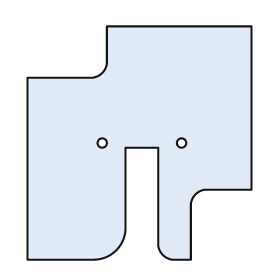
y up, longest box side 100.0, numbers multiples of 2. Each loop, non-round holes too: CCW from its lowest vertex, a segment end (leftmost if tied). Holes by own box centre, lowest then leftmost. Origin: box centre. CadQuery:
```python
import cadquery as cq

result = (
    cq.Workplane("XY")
    .moveTo(-48.0, -50.0)
    .lineTo(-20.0, -50.0)
    .threePointArc((-10.0, -46.0), (-6.0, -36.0))
    .lineTo(-6.0, -2.0)
    .lineTo(8.0, -2.0)
    .lineTo(8.0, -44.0)
    .threePointArc((10.0, -48.0), (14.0, -50.0))
    .lineTo(22.0, -50.0)
    .lineTo(22.0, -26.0)
    .threePointArc((24.0, -22.0), (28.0, -20.0))
    .lineTo(48.0, -20.0)
    .lineTo(48.0, 50.0)
    .lineTo(-14.0, 50.0)
    .lineTo(-14.0, 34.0)
    .threePointArc((-16.0, 30.0), (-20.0, 28.0))
    .lineTo(-48.0, 28.0)
    .close()
    .moveTo(-16.0, 0.0)
    .circle(2.0)
    .moveTo(18.0, 0.0)
    .circle(2.0)
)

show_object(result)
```